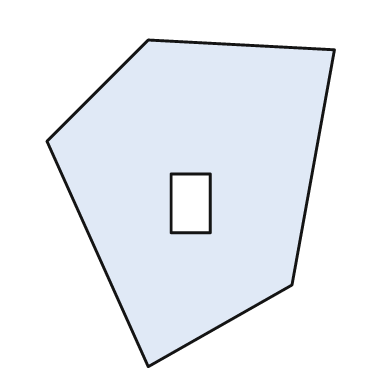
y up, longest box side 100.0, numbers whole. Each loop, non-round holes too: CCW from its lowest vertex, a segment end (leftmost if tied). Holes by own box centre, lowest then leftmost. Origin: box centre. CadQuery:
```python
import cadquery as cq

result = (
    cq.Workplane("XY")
    .moveTo(-13.0, -50.0)
    .lineTo(31.0, -25.0)
    .lineTo(44.0, 47.0)
    .lineTo(-13.0, 50.0)
    .lineTo(-44.0, 19.0)
    .close()
    .moveTo(-6.0, -9.0)
    .lineTo(6.0, -9.0)
    .lineTo(6.0, 9.0)
    .lineTo(-6.0, 9.0)
    .close()
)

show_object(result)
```